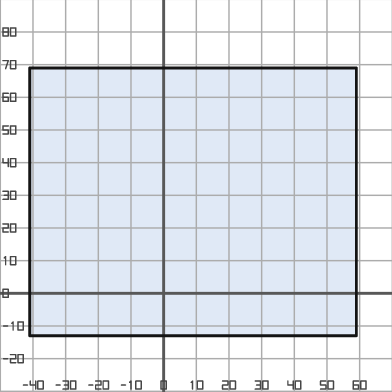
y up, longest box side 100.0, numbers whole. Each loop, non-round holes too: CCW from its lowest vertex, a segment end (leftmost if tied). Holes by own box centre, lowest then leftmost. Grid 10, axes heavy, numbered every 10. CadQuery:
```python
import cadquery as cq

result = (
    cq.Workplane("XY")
    .moveTo(-41.0, -13.0)
    .lineTo(59.0, -13.0)
    .lineTo(59.0, 69.0)
    .lineTo(-41.0, 69.0)
    .close()
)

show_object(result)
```